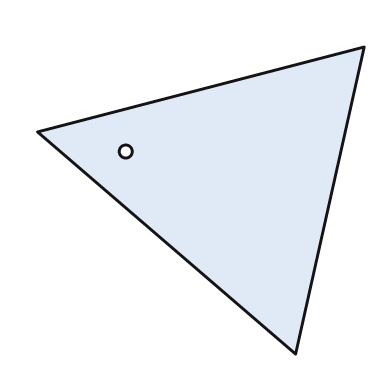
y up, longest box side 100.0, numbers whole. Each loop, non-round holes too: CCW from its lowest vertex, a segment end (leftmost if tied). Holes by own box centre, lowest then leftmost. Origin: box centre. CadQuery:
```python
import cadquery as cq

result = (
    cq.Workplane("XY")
    .moveTo(29.0, -47.0)
    .lineTo(50.0, 47.0)
    .lineTo(-50.0, 21.0)
    .close()
    .moveTo(-23.0, 15.0)
    .circle(2.0)
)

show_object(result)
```